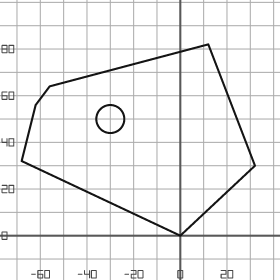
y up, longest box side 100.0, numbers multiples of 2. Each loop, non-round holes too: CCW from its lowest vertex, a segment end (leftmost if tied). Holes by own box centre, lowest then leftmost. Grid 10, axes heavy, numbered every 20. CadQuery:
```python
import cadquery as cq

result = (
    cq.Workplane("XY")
    .moveTo(0.0, 0.0)
    .lineTo(32.0, 30.0)
    .lineTo(12.0, 82.0)
    .lineTo(-56.0, 64.0)
    .lineTo(-62.0, 56.0)
    .lineTo(-68.0, 32.0)
    .close()
    .moveTo(-30.0, 50.0)
    .circle(6.0)
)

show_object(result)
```